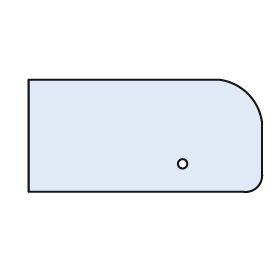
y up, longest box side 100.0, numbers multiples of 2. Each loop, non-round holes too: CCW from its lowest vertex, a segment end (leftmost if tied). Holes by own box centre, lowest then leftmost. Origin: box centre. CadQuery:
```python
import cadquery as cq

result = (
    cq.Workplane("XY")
    .moveTo(-50.0, -24.0)
    .lineTo(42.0, -24.0)
    .threePointArc((48.0, -22.0), (50.0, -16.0))
    .lineTo(50.0, 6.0)
    .threePointArc((44.0, 18.0), (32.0, 24.0))
    .lineTo(-50.0, 24.0)
    .close()
    .moveTo(16.0, -12.0)
    .circle(2.0)
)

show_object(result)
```